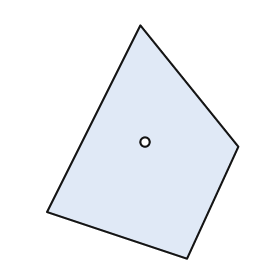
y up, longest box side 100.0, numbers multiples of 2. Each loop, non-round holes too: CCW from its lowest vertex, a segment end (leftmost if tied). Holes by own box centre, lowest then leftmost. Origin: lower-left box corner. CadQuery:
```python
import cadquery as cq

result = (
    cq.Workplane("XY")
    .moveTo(60.0, 0.0)
    .lineTo(82.0, 48.0)
    .lineTo(40.0, 100.0)
    .lineTo(0.0, 20.0)
    .close()
    .moveTo(42.0, 50.0)
    .circle(2.0)
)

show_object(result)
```